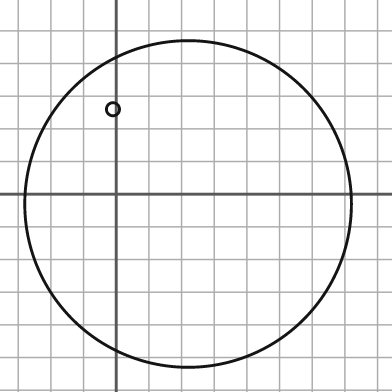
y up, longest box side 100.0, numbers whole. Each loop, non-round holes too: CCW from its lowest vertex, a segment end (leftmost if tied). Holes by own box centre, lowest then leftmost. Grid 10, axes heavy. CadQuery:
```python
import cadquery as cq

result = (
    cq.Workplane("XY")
    .moveTo(22.0, -3.0)
    .circle(50.0)
    .moveTo(-1.0, 26.0)
    .circle(2.0)
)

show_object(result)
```